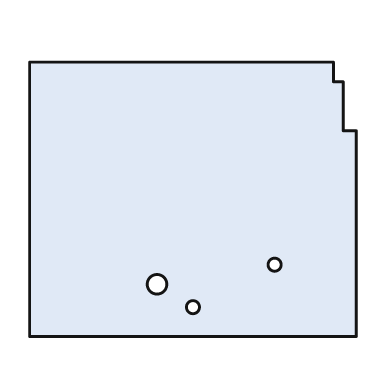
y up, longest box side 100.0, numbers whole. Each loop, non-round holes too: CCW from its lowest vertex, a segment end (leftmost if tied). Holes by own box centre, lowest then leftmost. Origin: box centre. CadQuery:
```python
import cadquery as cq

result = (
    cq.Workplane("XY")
    .moveTo(-50.0, -42.0)
    .lineTo(50.0, -42.0)
    .lineTo(50.0, 21.0)
    .lineTo(46.0, 21.0)
    .lineTo(46.0, 36.0)
    .lineTo(43.0, 36.0)
    .lineTo(43.0, 42.0)
    .lineTo(-50.0, 42.0)
    .close()
    .moveTo(0.0, -33.0)
    .circle(2.0)
    .moveTo(-11.0, -26.0)
    .circle(3.0)
    .moveTo(25.0, -20.0)
    .circle(2.0)
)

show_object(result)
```